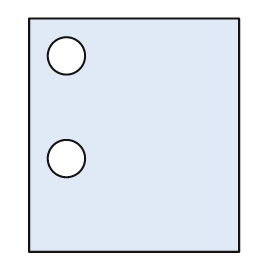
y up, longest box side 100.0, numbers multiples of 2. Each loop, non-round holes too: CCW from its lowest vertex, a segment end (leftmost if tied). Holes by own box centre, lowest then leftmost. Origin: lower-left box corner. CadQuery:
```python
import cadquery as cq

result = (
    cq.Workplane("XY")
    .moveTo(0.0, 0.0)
    .lineTo(90.0, 0.0)
    .lineTo(90.0, 100.0)
    .lineTo(0.0, 100.0)
    .close()
    .moveTo(16.0, 40.0)
    .circle(8.0)
    .moveTo(16.0, 84.0)
    .circle(8.0)
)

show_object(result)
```